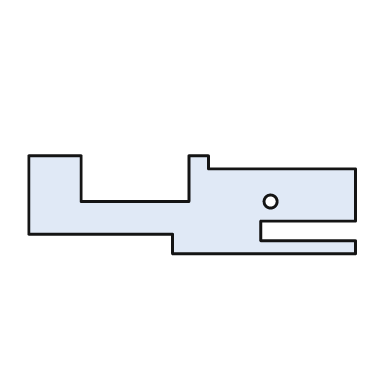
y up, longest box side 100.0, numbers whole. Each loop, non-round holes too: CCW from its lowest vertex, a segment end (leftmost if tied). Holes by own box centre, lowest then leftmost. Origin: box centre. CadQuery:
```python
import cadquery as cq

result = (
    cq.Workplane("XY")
    .moveTo(-6.0, -15.0)
    .lineTo(50.0, -15.0)
    .lineTo(50.0, -11.0)
    .lineTo(21.0, -11.0)
    .lineTo(21.0, -5.0)
    .lineTo(50.0, -5.0)
    .lineTo(50.0, 11.0)
    .lineTo(5.0, 11.0)
    .lineTo(5.0, 15.0)
    .lineTo(-1.0, 15.0)
    .lineTo(-1.0, 1.0)
    .lineTo(-34.0, 1.0)
    .lineTo(-34.0, 15.0)
    .lineTo(-50.0, 15.0)
    .lineTo(-50.0, -9.0)
    .lineTo(-6.0, -9.0)
    .close()
    .moveTo(24.0, 1.0)
    .circle(2.0)
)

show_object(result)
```